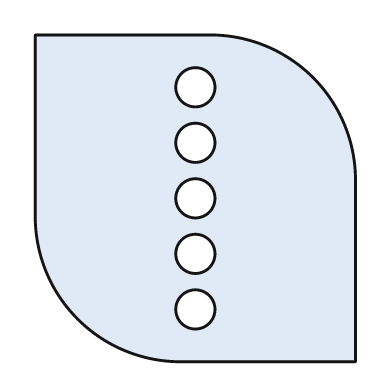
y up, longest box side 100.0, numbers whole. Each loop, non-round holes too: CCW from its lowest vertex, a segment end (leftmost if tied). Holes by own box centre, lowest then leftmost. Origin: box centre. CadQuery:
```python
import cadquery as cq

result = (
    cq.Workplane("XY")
    .moveTo(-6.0, -50.0)
    .lineTo(49.0, -50.0)
    .lineTo(49.0, 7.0)
    .threePointArc((36.0, 37.0), (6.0, 50.0))
    .lineTo(-49.0, 50.0)
    .lineTo(-49.0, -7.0)
    .threePointArc((-36.0, -37.0), (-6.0, -50.0))
    .close()
    .moveTo(0.0, -34.0)
    .circle(6.0)
    .moveTo(0.0, -17.0)
    .circle(6.0)
    .moveTo(0.0, 0.0)
    .circle(6.0)
    .moveTo(0.0, 17.0)
    .circle(6.0)
    .moveTo(0.0, 34.0)
    .circle(6.0)
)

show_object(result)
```